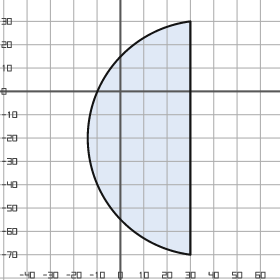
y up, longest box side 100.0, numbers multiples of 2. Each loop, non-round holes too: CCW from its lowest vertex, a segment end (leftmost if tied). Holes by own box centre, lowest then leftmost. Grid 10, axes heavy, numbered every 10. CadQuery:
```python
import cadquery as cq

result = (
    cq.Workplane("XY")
    .moveTo(30.0, -70.0)
    .lineTo(30.0, 30.0)
    .threePointArc((-14.0, -20.0), (30.0, -70.0))
    .close()
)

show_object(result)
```